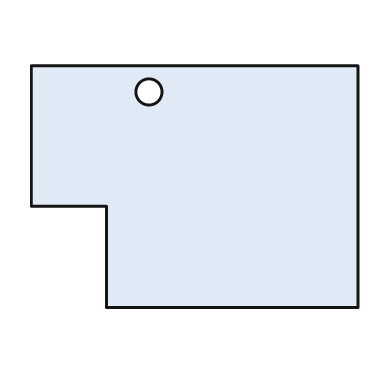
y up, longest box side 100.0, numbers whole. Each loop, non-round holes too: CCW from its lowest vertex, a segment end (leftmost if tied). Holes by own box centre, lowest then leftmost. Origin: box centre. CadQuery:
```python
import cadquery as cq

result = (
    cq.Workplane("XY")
    .moveTo(-27.0, -37.0)
    .lineTo(50.0, -37.0)
    .lineTo(50.0, 37.0)
    .lineTo(-50.0, 37.0)
    .lineTo(-50.0, -6.0)
    .lineTo(-27.0, -6.0)
    .close()
    .moveTo(-14.0, 29.0)
    .circle(4.0)
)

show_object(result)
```